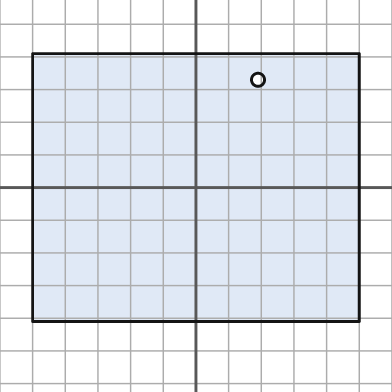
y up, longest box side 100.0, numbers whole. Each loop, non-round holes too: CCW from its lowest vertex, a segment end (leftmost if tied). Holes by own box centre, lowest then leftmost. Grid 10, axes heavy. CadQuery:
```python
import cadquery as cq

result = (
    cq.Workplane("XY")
    .moveTo(-50.0, -41.0)
    .lineTo(50.0, -41.0)
    .lineTo(50.0, 41.0)
    .lineTo(-50.0, 41.0)
    .close()
    .moveTo(19.0, 33.0)
    .circle(2.0)
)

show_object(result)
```